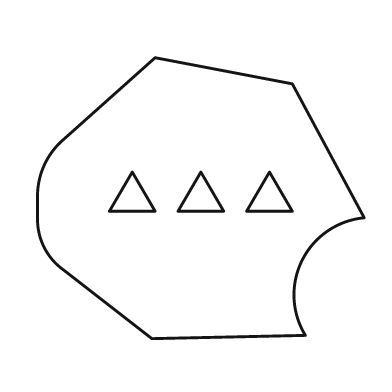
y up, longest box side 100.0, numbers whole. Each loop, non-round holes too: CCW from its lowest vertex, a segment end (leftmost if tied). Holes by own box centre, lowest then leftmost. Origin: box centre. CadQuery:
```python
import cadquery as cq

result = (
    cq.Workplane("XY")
    .moveTo(-15.0, -43.0)
    .lineTo(32.0, -42.0)
    .threePointArc((31.0, -19.0), (50.0, -6.0))
    .lineTo(28.0, 35.0)
    .lineTo(-14.0, 43.0)
    .lineTo(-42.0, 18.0)
    .threePointArc((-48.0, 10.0), (-50.0, 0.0))
    .lineTo(-50.0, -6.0)
    .threePointArc((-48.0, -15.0), (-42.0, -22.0))
    .close()
    .moveTo(-28.0, -4.0)
    .lineTo(-14.0, -4.0)
    .lineTo(-21.0, 8.0)
    .close()
    .moveTo(-7.0, -4.0)
    .lineTo(7.0, -4.0)
    .lineTo(0.0, 8.0)
    .close()
    .moveTo(14.0, -4.0)
    .lineTo(28.0, -4.0)
    .lineTo(21.0, 8.0)
    .close()
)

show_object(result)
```